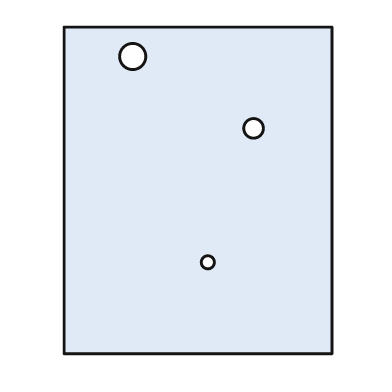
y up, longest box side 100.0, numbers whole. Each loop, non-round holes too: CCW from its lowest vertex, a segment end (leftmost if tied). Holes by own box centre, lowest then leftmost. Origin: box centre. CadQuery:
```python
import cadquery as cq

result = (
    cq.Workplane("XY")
    .moveTo(-41.0, -50.0)
    .lineTo(41.0, -50.0)
    .lineTo(41.0, 50.0)
    .lineTo(-41.0, 50.0)
    .close()
    .moveTo(3.0, -22.0)
    .circle(2.0)
    .moveTo(17.0, 19.0)
    .circle(3.0)
    .moveTo(-20.0, 41.0)
    .circle(4.0)
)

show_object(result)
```